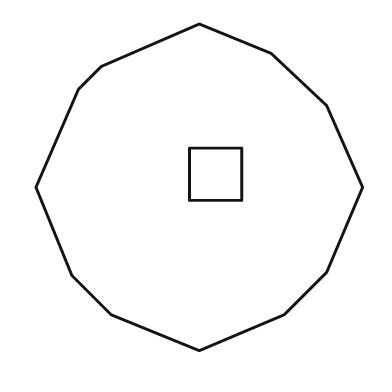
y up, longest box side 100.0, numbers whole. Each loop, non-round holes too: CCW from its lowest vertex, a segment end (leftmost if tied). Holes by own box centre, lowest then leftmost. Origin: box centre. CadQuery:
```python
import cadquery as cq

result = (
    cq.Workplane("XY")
    .moveTo(0.0, -50.0)
    .lineTo(26.0, -39.0)
    .lineTo(39.0, -26.0)
    .lineTo(50.0, 0.0)
    .lineTo(39.0, 25.0)
    .lineTo(22.0, 41.0)
    .lineTo(0.0, 50.0)
    .lineTo(-30.0, 37.0)
    .lineTo(-37.0, 30.0)
    .lineTo(-50.0, 0.0)
    .lineTo(-39.0, -27.0)
    .lineTo(-27.0, -39.0)
    .close()
    .moveTo(-3.0, -4.0)
    .lineTo(13.0, -4.0)
    .lineTo(13.0, 12.0)
    .lineTo(-3.0, 12.0)
    .close()
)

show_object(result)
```